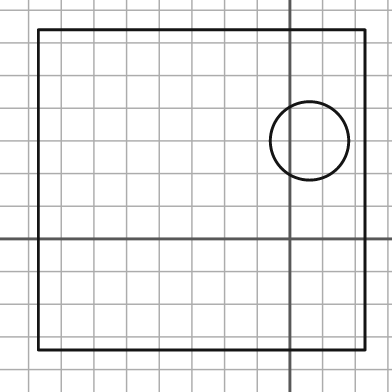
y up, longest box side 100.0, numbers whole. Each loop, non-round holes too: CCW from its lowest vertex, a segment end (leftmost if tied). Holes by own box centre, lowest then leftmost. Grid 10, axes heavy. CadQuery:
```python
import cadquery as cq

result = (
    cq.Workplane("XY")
    .moveTo(-77.0, -34.0)
    .lineTo(23.0, -34.0)
    .lineTo(23.0, 64.0)
    .lineTo(-77.0, 64.0)
    .close()
    .moveTo(6.0, 30.0)
    .circle(12.0)
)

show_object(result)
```